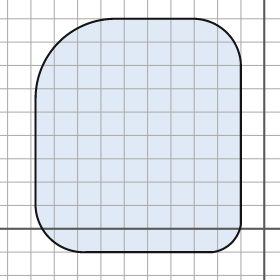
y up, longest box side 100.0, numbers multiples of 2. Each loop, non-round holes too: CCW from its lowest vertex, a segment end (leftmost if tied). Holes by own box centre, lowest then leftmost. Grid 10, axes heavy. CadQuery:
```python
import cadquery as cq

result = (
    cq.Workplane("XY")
    .moveTo(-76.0, -10.0)
    .lineTo(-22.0, -10.0)
    .threePointArc((-14.0, -6.0), (-10.0, 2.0))
    .lineTo(-10.0, 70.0)
    .threePointArc((-16.0, 84.0), (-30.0, 90.0))
    .lineTo(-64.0, 90.0)
    .threePointArc((-88.0, 80.0), (-98.0, 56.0))
    .lineTo(-98.0, 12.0)
    .threePointArc((-92.0, -4.0), (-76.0, -10.0))
    .close()
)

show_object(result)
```